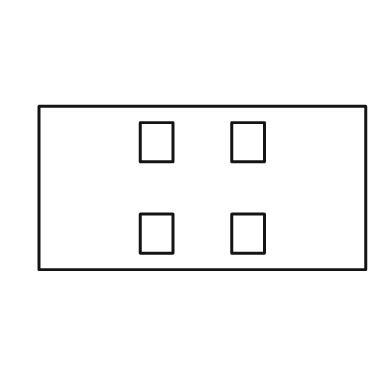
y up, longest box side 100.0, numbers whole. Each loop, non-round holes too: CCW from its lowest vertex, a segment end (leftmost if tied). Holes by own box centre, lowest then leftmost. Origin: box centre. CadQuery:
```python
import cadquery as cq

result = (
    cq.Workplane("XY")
    .moveTo(-50.0, -25.0)
    .lineTo(50.0, -25.0)
    .lineTo(50.0, 25.0)
    .lineTo(-50.0, 25.0)
    .close()
    .moveTo(-19.0, -20.0)
    .lineTo(-9.0, -20.0)
    .lineTo(-9.0, -8.0)
    .lineTo(-19.0, -8.0)
    .close()
    .moveTo(9.0, -20.0)
    .lineTo(19.0, -20.0)
    .lineTo(19.0, -8.0)
    .lineTo(9.0, -8.0)
    .close()
    .moveTo(-19.0, 8.0)
    .lineTo(-9.0, 8.0)
    .lineTo(-9.0, 20.0)
    .lineTo(-19.0, 20.0)
    .close()
    .moveTo(9.0, 8.0)
    .lineTo(19.0, 8.0)
    .lineTo(19.0, 20.0)
    .lineTo(9.0, 20.0)
    .close()
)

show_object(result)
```